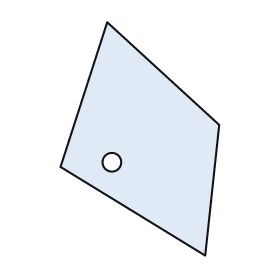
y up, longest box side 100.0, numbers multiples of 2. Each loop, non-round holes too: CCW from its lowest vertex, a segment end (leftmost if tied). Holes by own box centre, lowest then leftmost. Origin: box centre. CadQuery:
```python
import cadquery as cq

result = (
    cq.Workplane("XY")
    .moveTo(28.0, -50.0)
    .lineTo(34.0, 6.0)
    .lineTo(-14.0, 50.0)
    .lineTo(-34.0, -12.0)
    .close()
    .moveTo(-12.0, -10.0)
    .circle(4.0)
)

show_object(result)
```